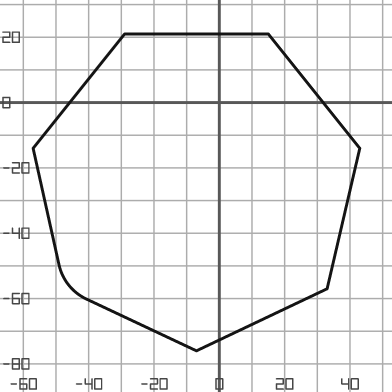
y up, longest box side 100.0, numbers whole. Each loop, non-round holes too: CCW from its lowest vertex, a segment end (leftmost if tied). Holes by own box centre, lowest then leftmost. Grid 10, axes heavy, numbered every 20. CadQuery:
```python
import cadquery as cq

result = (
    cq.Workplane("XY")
    .moveTo(-7.0, -76.0)
    .lineTo(33.0, -57.0)
    .lineTo(43.0, -14.0)
    .lineTo(15.0, 21.0)
    .lineTo(-29.0, 21.0)
    .lineTo(-57.0, -14.0)
    .lineTo(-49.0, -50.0)
    .threePointArc((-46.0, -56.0), (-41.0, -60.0))
    .close()
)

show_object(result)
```